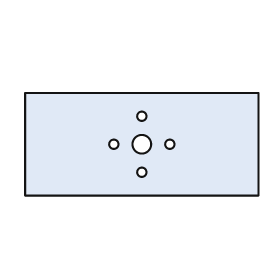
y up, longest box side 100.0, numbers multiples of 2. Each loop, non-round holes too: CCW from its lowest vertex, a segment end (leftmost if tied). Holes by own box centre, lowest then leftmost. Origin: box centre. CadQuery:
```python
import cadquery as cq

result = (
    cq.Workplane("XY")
    .moveTo(-50.0, -22.0)
    .lineTo(50.0, -22.0)
    .lineTo(50.0, 22.0)
    .lineTo(-50.0, 22.0)
    .close()
    .moveTo(0.0, -12.0)
    .circle(2.0)
    .moveTo(-12.0, 0.0)
    .circle(2.0)
    .moveTo(0.0, 0.0)
    .circle(4.0)
    .moveTo(12.0, 0.0)
    .circle(2.0)
    .moveTo(0.0, 12.0)
    .circle(2.0)
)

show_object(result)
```